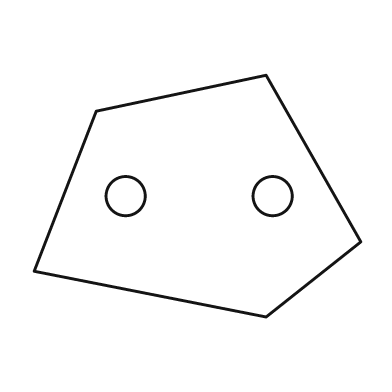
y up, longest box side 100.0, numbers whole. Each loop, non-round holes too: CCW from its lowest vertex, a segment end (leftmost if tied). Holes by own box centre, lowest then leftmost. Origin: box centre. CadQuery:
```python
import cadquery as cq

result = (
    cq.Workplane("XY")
    .moveTo(21.0, -37.0)
    .lineTo(50.0, -14.0)
    .lineTo(21.0, 37.0)
    .lineTo(-31.0, 26.0)
    .lineTo(-50.0, -23.0)
    .close()
    .moveTo(-22.0, 0.0)
    .circle(6.0)
    .moveTo(23.0, 0.0)
    .circle(6.0)
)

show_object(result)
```